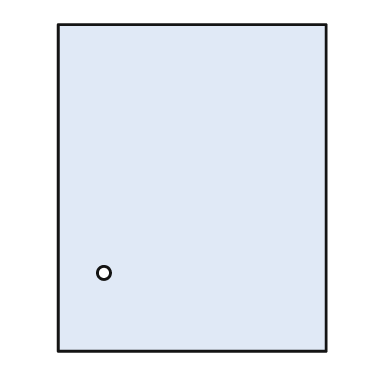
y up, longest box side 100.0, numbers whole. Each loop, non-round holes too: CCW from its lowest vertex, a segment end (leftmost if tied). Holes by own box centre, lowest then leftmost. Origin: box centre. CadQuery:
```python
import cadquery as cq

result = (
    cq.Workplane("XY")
    .moveTo(-41.0, -50.0)
    .lineTo(41.0, -50.0)
    .lineTo(41.0, 50.0)
    .lineTo(-41.0, 50.0)
    .close()
    .moveTo(-27.0, -26.0)
    .circle(2.0)
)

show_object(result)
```